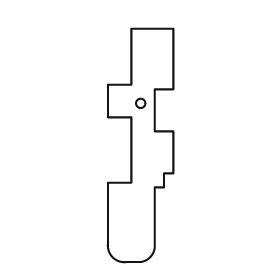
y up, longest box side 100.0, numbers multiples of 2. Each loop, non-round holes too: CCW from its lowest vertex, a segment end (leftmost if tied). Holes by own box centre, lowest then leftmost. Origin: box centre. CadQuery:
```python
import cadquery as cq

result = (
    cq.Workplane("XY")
    .moveTo(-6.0, -50.0)
    .lineTo(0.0, -50.0)
    .threePointArc((4.0, -48.0), (6.0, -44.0))
    .lineTo(6.0, -18.0)
    .lineTo(10.0, -18.0)
    .lineTo(10.0, -12.0)
    .lineTo(14.0, -12.0)
    .lineTo(14.0, 6.0)
    .lineTo(6.0, 6.0)
    .lineTo(6.0, 24.0)
    .lineTo(14.0, 24.0)
    .lineTo(14.0, 50.0)
    .lineTo(-4.0, 50.0)
    .lineTo(-4.0, 26.0)
    .lineTo(-14.0, 26.0)
    .lineTo(-14.0, 12.0)
    .lineTo(-4.0, 12.0)
    .lineTo(-4.0, -16.0)
    .lineTo(-14.0, -16.0)
    .lineTo(-14.0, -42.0)
    .threePointArc((-12.0, -48.0), (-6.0, -50.0))
    .close()
    .moveTo(0.0, 18.0)
    .circle(2.0)
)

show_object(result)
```